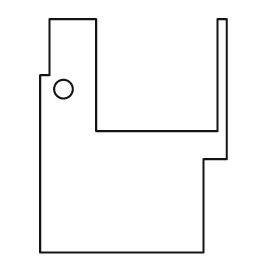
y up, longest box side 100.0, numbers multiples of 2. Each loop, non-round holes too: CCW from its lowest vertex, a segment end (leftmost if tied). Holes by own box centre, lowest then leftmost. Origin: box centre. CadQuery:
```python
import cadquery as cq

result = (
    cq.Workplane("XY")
    .moveTo(-40.0, -50.0)
    .lineTo(30.0, -50.0)
    .lineTo(30.0, -10.0)
    .lineTo(40.0, -10.0)
    .lineTo(40.0, 50.0)
    .lineTo(36.0, 50.0)
    .lineTo(36.0, 2.0)
    .lineTo(-16.0, 2.0)
    .lineTo(-16.0, 50.0)
    .lineTo(-36.0, 50.0)
    .lineTo(-36.0, 26.0)
    .lineTo(-40.0, 26.0)
    .close()
    .moveTo(-30.0, 20.0)
    .circle(4.0)
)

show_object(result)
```